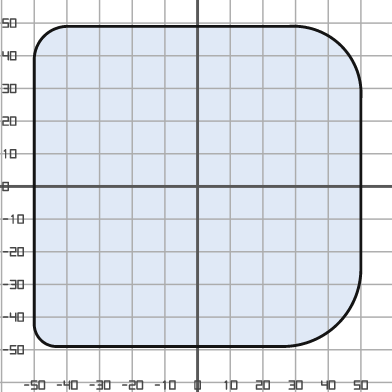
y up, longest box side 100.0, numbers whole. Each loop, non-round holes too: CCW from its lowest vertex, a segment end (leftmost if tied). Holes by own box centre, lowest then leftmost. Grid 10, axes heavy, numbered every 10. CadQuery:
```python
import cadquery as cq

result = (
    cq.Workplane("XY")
    .moveTo(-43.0, -49.0)
    .lineTo(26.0, -49.0)
    .threePointArc((43.0, -42.0), (50.0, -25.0))
    .lineTo(50.0, 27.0)
    .threePointArc((44.0, 43.0), (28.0, 49.0))
    .lineTo(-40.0, 49.0)
    .threePointArc((-47.0, 46.0), (-50.0, 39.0))
    .lineTo(-50.0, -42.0)
    .threePointArc((-48.0, -47.0), (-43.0, -49.0))
    .close()
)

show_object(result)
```